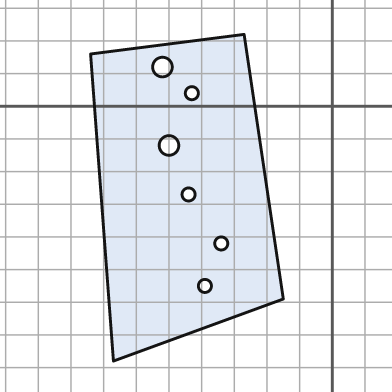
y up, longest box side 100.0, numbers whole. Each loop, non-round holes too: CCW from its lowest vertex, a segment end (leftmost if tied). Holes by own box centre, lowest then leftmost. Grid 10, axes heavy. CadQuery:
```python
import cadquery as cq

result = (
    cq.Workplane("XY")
    .moveTo(-67.0, -78.0)
    .lineTo(-15.0, -59.0)
    .lineTo(-27.0, 22.0)
    .lineTo(-74.0, 16.0)
    .close()
    .moveTo(-39.0, -55.0)
    .circle(2.0)
    .moveTo(-34.0, -42.0)
    .circle(2.0)
    .moveTo(-44.0, -27.0)
    .circle(2.0)
    .moveTo(-50.0, -12.0)
    .circle(3.0)
    .moveTo(-43.0, 4.0)
    .circle(2.0)
    .moveTo(-52.0, 12.0)
    .circle(3.0)
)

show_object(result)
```